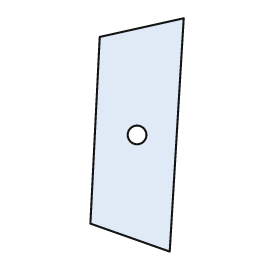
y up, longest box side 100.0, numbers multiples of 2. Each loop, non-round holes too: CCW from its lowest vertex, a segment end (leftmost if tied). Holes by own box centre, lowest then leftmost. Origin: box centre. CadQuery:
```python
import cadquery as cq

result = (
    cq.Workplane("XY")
    .moveTo(14.0, -50.0)
    .lineTo(20.0, 50.0)
    .lineTo(-16.0, 42.0)
    .lineTo(-20.0, -38.0)
    .close()
    .moveTo(0.0, 0.0)
    .circle(4.0)
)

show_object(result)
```